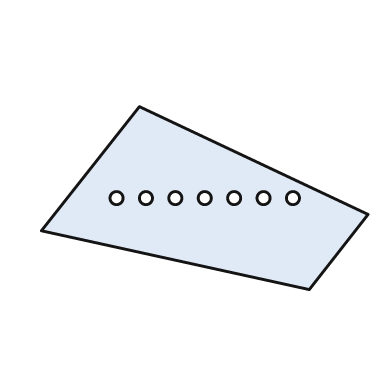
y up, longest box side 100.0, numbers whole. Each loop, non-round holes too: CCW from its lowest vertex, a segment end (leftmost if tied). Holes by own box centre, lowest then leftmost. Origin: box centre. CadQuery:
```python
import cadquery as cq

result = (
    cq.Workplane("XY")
    .moveTo(32.0, -28.0)
    .lineTo(50.0, -5.0)
    .lineTo(-20.0, 28.0)
    .lineTo(-50.0, -10.0)
    .close()
    .moveTo(-27.0, 0.0)
    .circle(2.0)
    .moveTo(-18.0, 0.0)
    .circle(2.0)
    .moveTo(-9.0, 0.0)
    .circle(2.0)
    .moveTo(0.0, 0.0)
    .circle(2.0)
    .moveTo(9.0, 0.0)
    .circle(2.0)
    .moveTo(18.0, 0.0)
    .circle(2.0)
    .moveTo(27.0, 0.0)
    .circle(2.0)
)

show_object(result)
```